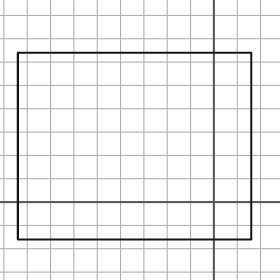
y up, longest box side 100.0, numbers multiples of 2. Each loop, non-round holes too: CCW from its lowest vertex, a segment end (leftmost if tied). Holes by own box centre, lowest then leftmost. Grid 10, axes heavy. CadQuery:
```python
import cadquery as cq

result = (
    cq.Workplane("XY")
    .moveTo(-84.0, -16.0)
    .lineTo(16.0, -16.0)
    .lineTo(16.0, 64.0)
    .lineTo(-84.0, 64.0)
    .close()
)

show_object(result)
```